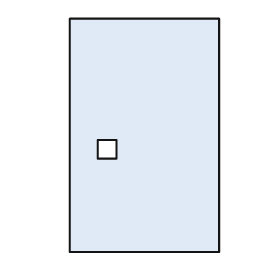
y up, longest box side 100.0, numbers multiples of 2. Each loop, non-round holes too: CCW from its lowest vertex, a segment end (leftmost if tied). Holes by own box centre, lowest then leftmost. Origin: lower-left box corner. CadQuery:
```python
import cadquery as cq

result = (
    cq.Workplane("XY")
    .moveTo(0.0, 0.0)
    .lineTo(64.0, 0.0)
    .lineTo(64.0, 100.0)
    .lineTo(0.0, 100.0)
    .close()
    .moveTo(12.0, 40.0)
    .lineTo(20.0, 40.0)
    .lineTo(20.0, 48.0)
    .lineTo(12.0, 48.0)
    .close()
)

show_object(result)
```